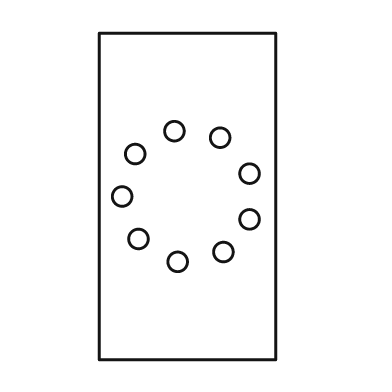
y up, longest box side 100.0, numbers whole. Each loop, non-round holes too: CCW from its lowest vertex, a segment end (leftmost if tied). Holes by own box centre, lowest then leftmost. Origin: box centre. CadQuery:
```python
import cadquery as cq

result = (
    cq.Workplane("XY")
    .moveTo(-27.0, -50.0)
    .lineTo(27.0, -50.0)
    .lineTo(27.0, 50.0)
    .lineTo(-27.0, 50.0)
    .close()
    .moveTo(-3.0, -20.0)
    .circle(3.0)
    .moveTo(11.0, -17.0)
    .circle(3.0)
    .moveTo(-15.0, -13.0)
    .circle(3.0)
    .moveTo(19.0, -7.0)
    .circle(3.0)
    .moveTo(-20.0, 0.0)
    .circle(3.0)
    .moveTo(19.0, 7.0)
    .circle(3.0)
    .moveTo(-16.0, 13.0)
    .circle(3.0)
    .moveTo(10.0, 18.0)
    .circle(3.0)
    .moveTo(-4.0, 20.0)
    .circle(3.0)
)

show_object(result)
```